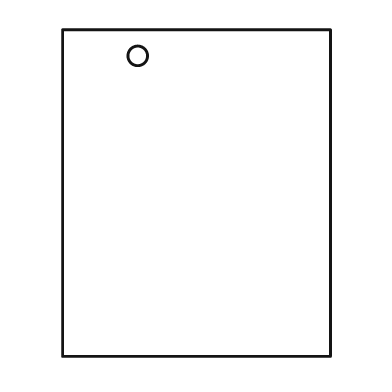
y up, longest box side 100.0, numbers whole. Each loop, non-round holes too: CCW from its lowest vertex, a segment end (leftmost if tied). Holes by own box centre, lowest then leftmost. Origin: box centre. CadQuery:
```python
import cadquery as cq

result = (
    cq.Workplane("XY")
    .moveTo(-41.0, -50.0)
    .lineTo(41.0, -50.0)
    .lineTo(41.0, 50.0)
    .lineTo(-41.0, 50.0)
    .close()
    .moveTo(-18.0, 42.0)
    .circle(3.0)
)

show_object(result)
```